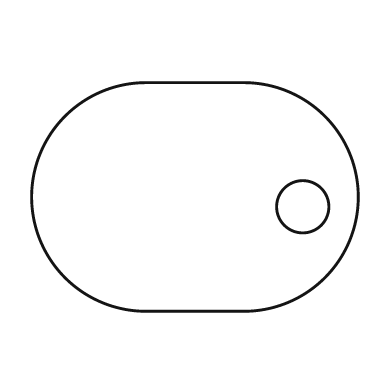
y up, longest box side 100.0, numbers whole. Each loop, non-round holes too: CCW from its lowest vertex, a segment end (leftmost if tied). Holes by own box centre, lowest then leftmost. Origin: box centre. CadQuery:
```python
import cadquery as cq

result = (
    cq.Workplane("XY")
    .moveTo(-15.0, -35.0)
    .lineTo(15.0, -35.0)
    .threePointArc((50.0, 0.0), (15.0, 35.0))
    .lineTo(-15.0, 35.0)
    .threePointArc((-50.0, 0.0), (-15.0, -35.0))
    .close()
    .moveTo(33.0, -3.0)
    .circle(8.0)
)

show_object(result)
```